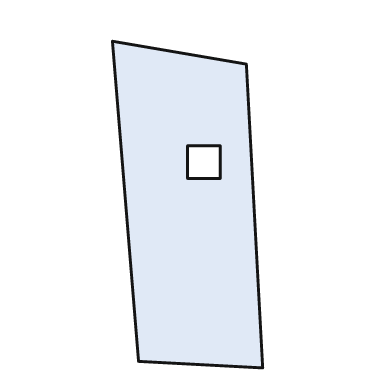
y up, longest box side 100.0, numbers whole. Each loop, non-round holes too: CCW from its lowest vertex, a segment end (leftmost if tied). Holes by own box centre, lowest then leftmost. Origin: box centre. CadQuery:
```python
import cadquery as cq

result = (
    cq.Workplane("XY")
    .moveTo(23.0, -50.0)
    .lineTo(18.0, 43.0)
    .lineTo(-23.0, 50.0)
    .lineTo(-15.0, -48.0)
    .close()
    .moveTo(0.0, 8.0)
    .lineTo(10.0, 8.0)
    .lineTo(10.0, 18.0)
    .lineTo(0.0, 18.0)
    .close()
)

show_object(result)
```